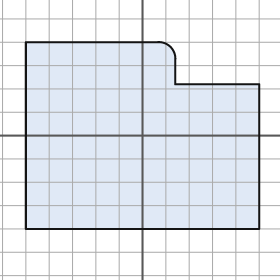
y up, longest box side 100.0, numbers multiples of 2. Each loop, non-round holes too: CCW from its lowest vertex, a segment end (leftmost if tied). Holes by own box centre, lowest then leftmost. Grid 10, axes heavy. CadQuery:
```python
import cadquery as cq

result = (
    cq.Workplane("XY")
    .moveTo(-50.0, -40.0)
    .lineTo(50.0, -40.0)
    .lineTo(50.0, 22.0)
    .lineTo(14.0, 22.0)
    .lineTo(14.0, 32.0)
    .threePointArc((12.0, 38.0), (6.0, 40.0))
    .lineTo(-50.0, 40.0)
    .close()
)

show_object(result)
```